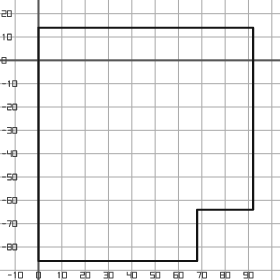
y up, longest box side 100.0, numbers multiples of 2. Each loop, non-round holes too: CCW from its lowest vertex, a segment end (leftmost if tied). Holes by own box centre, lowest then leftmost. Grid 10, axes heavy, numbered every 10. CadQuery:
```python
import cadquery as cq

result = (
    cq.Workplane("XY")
    .moveTo(0.0, -86.0)
    .lineTo(68.0, -86.0)
    .lineTo(68.0, -64.0)
    .lineTo(92.0, -64.0)
    .lineTo(92.0, 14.0)
    .lineTo(0.0, 14.0)
    .close()
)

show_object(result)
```